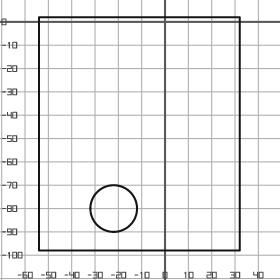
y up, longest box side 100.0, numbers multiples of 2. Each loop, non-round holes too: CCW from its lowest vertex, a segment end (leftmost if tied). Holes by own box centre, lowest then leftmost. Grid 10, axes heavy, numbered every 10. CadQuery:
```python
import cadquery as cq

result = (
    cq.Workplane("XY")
    .moveTo(-54.0, -98.0)
    .lineTo(32.0, -98.0)
    .lineTo(32.0, 2.0)
    .lineTo(-54.0, 2.0)
    .close()
    .moveTo(-22.0, -80.0)
    .circle(10.0)
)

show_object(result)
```